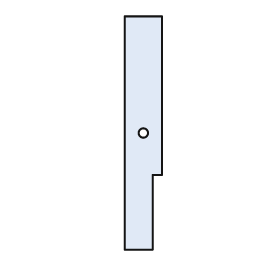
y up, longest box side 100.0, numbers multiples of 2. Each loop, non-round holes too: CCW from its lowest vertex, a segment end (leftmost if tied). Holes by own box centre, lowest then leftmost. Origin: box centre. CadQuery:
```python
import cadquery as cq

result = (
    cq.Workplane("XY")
    .moveTo(-8.0, -50.0)
    .lineTo(4.0, -50.0)
    .lineTo(4.0, -18.0)
    .lineTo(8.0, -18.0)
    .lineTo(8.0, 50.0)
    .lineTo(-8.0, 50.0)
    .close()
    .moveTo(0.0, 0.0)
    .circle(2.0)
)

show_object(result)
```